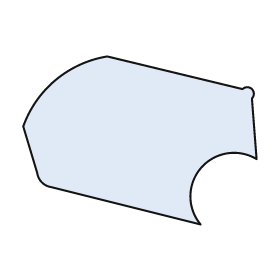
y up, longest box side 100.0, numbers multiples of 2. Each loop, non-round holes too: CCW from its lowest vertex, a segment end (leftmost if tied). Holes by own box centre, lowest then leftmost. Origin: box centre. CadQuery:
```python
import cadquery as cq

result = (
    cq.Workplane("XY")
    .moveTo(26.0, -36.0)
    .threePointArc((26.0, -12.0), (50.0, -8.0))
    .lineTo(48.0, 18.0)
    .threePointArc((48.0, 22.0), (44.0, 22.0))
    .lineTo(-14.0, 36.0)
    .threePointArc((-36.0, 26.0), (-50.0, 6.0))
    .lineTo(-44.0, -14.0)
    .threePointArc((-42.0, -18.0), (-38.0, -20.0))
    .close()
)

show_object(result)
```